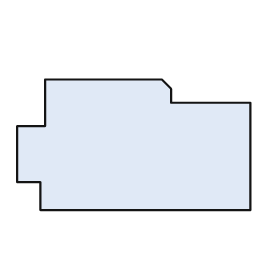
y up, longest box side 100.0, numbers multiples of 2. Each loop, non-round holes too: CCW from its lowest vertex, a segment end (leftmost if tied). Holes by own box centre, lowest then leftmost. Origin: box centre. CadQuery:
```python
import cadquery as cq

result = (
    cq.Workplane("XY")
    .moveTo(-40.0, -28.0)
    .lineTo(50.0, -28.0)
    .lineTo(50.0, 18.0)
    .lineTo(16.0, 18.0)
    .lineTo(16.0, 24.0)
    .lineTo(12.0, 28.0)
    .lineTo(-38.0, 28.0)
    .lineTo(-38.0, 8.0)
    .lineTo(-50.0, 8.0)
    .lineTo(-50.0, -16.0)
    .lineTo(-40.0, -16.0)
    .close()
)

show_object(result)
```